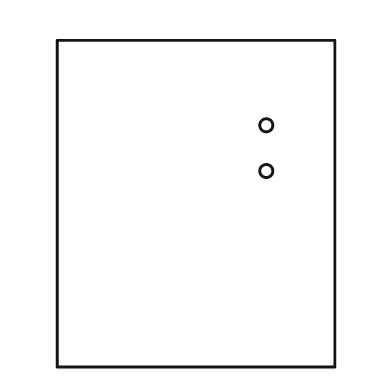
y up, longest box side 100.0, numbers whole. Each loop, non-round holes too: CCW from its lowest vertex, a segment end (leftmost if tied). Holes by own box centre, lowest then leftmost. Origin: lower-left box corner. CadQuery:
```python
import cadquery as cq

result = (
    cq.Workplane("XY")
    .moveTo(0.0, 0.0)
    .lineTo(85.0, 0.0)
    .lineTo(85.0, 100.0)
    .lineTo(0.0, 100.0)
    .close()
    .moveTo(64.0, 60.0)
    .circle(2.0)
    .moveTo(64.0, 74.0)
    .circle(2.0)
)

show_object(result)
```